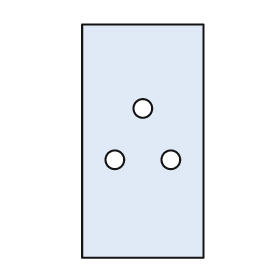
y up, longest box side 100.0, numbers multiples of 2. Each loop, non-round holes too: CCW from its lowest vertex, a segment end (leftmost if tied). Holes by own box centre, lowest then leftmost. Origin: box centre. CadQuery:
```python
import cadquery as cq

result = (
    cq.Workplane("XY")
    .moveTo(-26.0, -50.0)
    .lineTo(26.0, -50.0)
    .lineTo(26.0, 50.0)
    .lineTo(-26.0, 50.0)
    .close()
    .moveTo(-12.0, -8.0)
    .circle(4.0)
    .moveTo(12.0, -8.0)
    .circle(4.0)
    .moveTo(0.0, 14.0)
    .circle(4.0)
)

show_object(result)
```